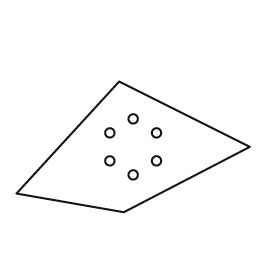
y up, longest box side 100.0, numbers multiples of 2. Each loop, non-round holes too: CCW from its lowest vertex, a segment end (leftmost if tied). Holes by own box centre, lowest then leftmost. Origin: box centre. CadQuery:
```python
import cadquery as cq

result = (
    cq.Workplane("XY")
    .moveTo(-4.0, -28.0)
    .lineTo(50.0, 0.0)
    .lineTo(-6.0, 28.0)
    .lineTo(-50.0, -20.0)
    .close()
    .moveTo(0.0, -12.0)
    .circle(2.0)
    .moveTo(-10.0, -6.0)
    .circle(2.0)
    .moveTo(10.0, -6.0)
    .circle(2.0)
    .moveTo(-10.0, 6.0)
    .circle(2.0)
    .moveTo(10.0, 6.0)
    .circle(2.0)
    .moveTo(0.0, 12.0)
    .circle(2.0)
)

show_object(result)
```